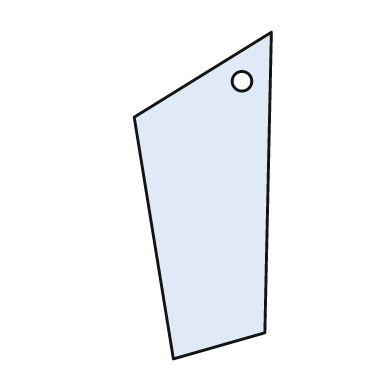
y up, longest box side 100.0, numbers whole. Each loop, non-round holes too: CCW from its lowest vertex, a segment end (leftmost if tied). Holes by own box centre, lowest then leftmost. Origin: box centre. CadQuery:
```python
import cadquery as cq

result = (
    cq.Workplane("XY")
    .moveTo(-9.0, -50.0)
    .lineTo(19.0, -42.0)
    .lineTo(21.0, 50.0)
    .lineTo(-21.0, 24.0)
    .close()
    .moveTo(12.0, 35.0)
    .circle(3.0)
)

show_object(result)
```